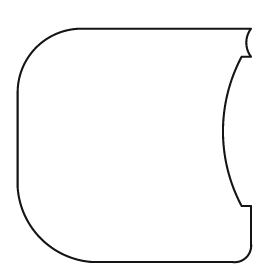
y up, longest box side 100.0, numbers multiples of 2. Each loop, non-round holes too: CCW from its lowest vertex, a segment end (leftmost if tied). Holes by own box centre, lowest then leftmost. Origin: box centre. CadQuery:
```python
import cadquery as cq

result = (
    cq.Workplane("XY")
    .moveTo(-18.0, -50.0)
    .lineTo(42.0, -50.0)
    .threePointArc((48.0, -48.0), (50.0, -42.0))
    .lineTo(50.0, -26.0)
    .lineTo(46.0, -26.0)
    .threePointArc((38.0, 6.0), (46.0, 38.0))
    .lineTo(50.0, 38.0)
    .threePointArc((48.0, 44.0), (50.0, 50.0))
    .lineTo(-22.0, 50.0)
    .threePointArc((-42.0, 42.0), (-50.0, 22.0))
    .lineTo(-50.0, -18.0)
    .threePointArc((-40.0, -40.0), (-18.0, -50.0))
    .close()
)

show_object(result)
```